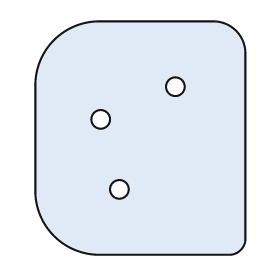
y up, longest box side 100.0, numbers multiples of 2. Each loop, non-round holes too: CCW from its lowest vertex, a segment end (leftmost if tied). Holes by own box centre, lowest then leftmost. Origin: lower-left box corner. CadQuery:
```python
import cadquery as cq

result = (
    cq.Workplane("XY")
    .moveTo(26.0, 0.0)
    .lineTo(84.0, 0.0)
    .threePointArc((88.0, 2.0), (90.0, 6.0))
    .lineTo(90.0, 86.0)
    .threePointArc((86.0, 96.0), (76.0, 100.0))
    .lineTo(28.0, 100.0)
    .threePointArc((8.0, 92.0), (0.0, 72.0))
    .lineTo(0.0, 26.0)
    .threePointArc((8.0, 8.0), (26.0, 0.0))
    .close()
    .moveTo(36.0, 28.0)
    .circle(4.0)
    .moveTo(28.0, 58.0)
    .circle(4.0)
    .moveTo(60.0, 72.0)
    .circle(4.0)
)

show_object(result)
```